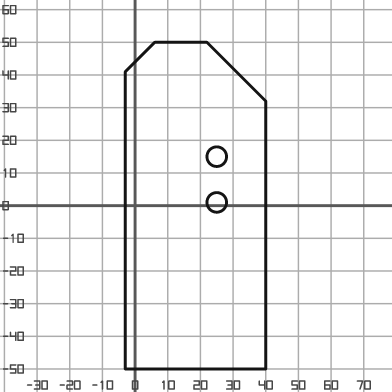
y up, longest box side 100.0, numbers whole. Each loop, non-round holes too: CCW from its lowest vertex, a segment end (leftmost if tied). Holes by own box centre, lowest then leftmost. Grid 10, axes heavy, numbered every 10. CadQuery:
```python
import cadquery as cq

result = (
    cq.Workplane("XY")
    .moveTo(-3.0, -50.0)
    .lineTo(40.0, -50.0)
    .lineTo(40.0, 32.0)
    .lineTo(22.0, 50.0)
    .lineTo(6.0, 50.0)
    .lineTo(-3.0, 41.0)
    .close()
    .moveTo(25.0, 1.0)
    .circle(3.0)
    .moveTo(25.0, 15.0)
    .circle(3.0)
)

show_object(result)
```